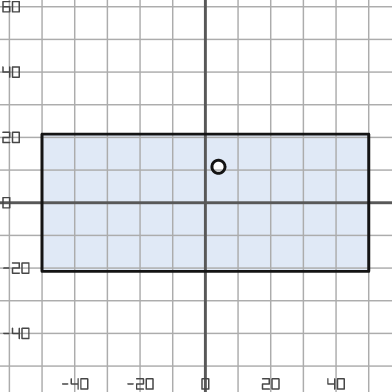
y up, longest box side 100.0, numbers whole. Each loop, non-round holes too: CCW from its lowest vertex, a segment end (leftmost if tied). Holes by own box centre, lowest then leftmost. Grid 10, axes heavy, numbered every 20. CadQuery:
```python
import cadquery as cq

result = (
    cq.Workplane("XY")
    .moveTo(-50.0, -21.0)
    .lineTo(50.0, -21.0)
    .lineTo(50.0, 21.0)
    .lineTo(-50.0, 21.0)
    .close()
    .moveTo(4.0, 11.0)
    .circle(2.0)
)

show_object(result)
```